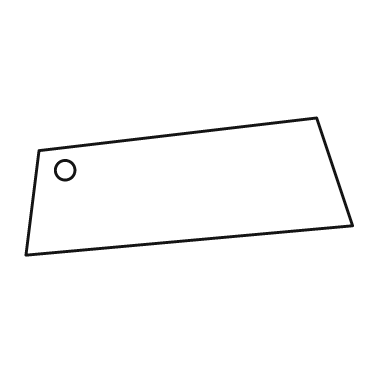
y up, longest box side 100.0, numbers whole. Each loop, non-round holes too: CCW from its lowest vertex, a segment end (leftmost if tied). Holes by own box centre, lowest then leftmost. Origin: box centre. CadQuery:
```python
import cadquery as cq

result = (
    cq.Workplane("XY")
    .moveTo(-50.0, -21.0)
    .lineTo(50.0, -12.0)
    .lineTo(39.0, 21.0)
    .lineTo(-46.0, 11.0)
    .close()
    .moveTo(-38.0, 5.0)
    .circle(3.0)
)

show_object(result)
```